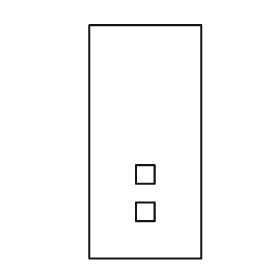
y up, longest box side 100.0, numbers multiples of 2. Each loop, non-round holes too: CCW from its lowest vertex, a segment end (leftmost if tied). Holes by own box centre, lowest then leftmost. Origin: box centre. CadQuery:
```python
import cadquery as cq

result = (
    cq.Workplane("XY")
    .moveTo(-24.0, -50.0)
    .lineTo(24.0, -50.0)
    .lineTo(24.0, 50.0)
    .lineTo(-24.0, 50.0)
    .close()
    .moveTo(-4.0, -34.0)
    .lineTo(4.0, -34.0)
    .lineTo(4.0, -26.0)
    .lineTo(-4.0, -26.0)
    .close()
    .moveTo(-4.0, -18.0)
    .lineTo(4.0, -18.0)
    .lineTo(4.0, -10.0)
    .lineTo(-4.0, -10.0)
    .close()
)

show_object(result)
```